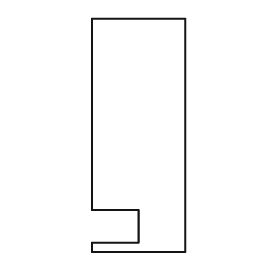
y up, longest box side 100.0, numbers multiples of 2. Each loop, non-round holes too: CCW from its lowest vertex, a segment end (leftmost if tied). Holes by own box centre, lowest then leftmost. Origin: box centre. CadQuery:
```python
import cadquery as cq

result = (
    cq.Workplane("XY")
    .moveTo(-20.0, -50.0)
    .lineTo(20.0, -50.0)
    .lineTo(20.0, 50.0)
    .lineTo(-20.0, 50.0)
    .lineTo(-20.0, -32.0)
    .lineTo(0.0, -32.0)
    .lineTo(0.0, -46.0)
    .lineTo(-20.0, -46.0)
    .close()
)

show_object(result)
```